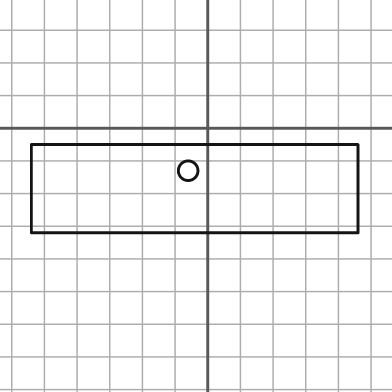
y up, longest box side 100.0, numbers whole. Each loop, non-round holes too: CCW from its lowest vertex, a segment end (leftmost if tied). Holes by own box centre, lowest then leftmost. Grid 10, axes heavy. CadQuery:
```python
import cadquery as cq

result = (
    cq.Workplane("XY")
    .moveTo(-54.0, -32.0)
    .lineTo(46.0, -32.0)
    .lineTo(46.0, -5.0)
    .lineTo(-54.0, -5.0)
    .close()
    .moveTo(-6.0, -13.0)
    .circle(3.0)
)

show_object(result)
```